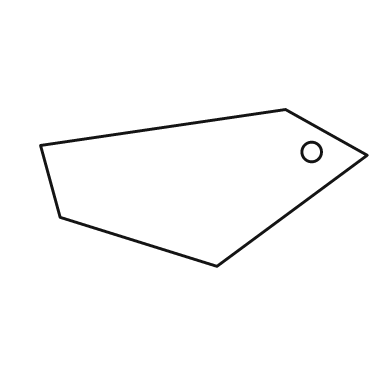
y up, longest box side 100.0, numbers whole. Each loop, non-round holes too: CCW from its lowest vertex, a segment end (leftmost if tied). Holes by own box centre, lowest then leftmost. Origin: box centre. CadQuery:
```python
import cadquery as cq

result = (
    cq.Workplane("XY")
    .moveTo(4.0, -24.0)
    .lineTo(50.0, 10.0)
    .lineTo(25.0, 24.0)
    .lineTo(-50.0, 13.0)
    .lineTo(-44.0, -9.0)
    .close()
    .moveTo(33.0, 11.0)
    .circle(3.0)
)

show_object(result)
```